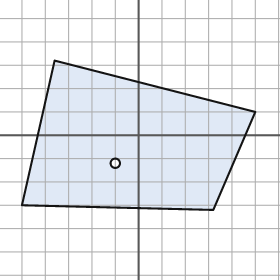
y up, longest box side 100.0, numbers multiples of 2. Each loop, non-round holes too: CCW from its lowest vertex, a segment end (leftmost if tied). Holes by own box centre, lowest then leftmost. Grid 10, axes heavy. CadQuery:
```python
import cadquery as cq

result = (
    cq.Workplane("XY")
    .moveTo(32.0, -32.0)
    .lineTo(50.0, 10.0)
    .lineTo(-36.0, 32.0)
    .lineTo(-50.0, -30.0)
    .close()
    .moveTo(-10.0, -12.0)
    .circle(2.0)
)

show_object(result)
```